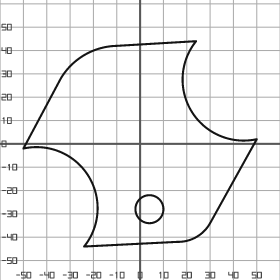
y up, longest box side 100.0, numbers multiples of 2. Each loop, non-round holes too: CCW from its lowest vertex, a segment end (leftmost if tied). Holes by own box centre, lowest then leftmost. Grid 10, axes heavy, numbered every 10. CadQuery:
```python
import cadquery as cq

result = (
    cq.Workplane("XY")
    .moveTo(-24.0, -44.0)
    .lineTo(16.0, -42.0)
    .threePointArc((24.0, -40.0), (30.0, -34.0))
    .lineTo(50.0, 2.0)
    .threePointArc((22.0, 14.0), (24.0, 44.0))
    .lineTo(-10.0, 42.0)
    .threePointArc((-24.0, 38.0), (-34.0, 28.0))
    .lineTo(-50.0, -2.0)
    .threePointArc((-22.0, -14.0), (-24.0, -44.0))
    .close()
    .moveTo(4.0, -28.0)
    .circle(6.0)
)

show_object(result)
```